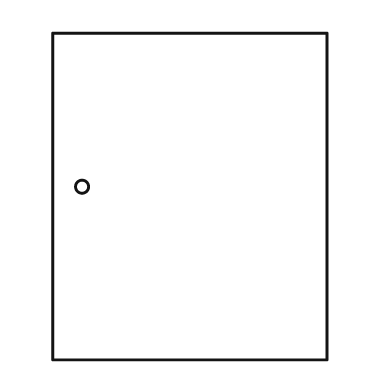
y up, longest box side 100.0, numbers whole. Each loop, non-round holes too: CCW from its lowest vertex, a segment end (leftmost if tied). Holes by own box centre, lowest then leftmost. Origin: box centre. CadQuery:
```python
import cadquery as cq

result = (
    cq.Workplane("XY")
    .moveTo(-42.0, -50.0)
    .lineTo(42.0, -50.0)
    .lineTo(42.0, 50.0)
    .lineTo(-42.0, 50.0)
    .close()
    .moveTo(-33.0, 3.0)
    .circle(2.0)
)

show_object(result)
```